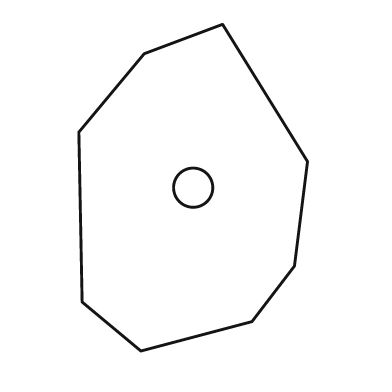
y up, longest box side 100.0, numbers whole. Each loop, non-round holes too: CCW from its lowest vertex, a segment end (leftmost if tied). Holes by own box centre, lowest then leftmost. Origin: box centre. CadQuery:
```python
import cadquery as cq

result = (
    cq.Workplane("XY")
    .moveTo(-16.0, -50.0)
    .lineTo(18.0, -41.0)
    .lineTo(31.0, -24.0)
    .lineTo(35.0, 8.0)
    .lineTo(9.0, 50.0)
    .lineTo(-15.0, 41.0)
    .lineTo(-35.0, 17.0)
    .lineTo(-34.0, -35.0)
    .close()
    .moveTo(0.0, 0.0)
    .circle(6.0)
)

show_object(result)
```